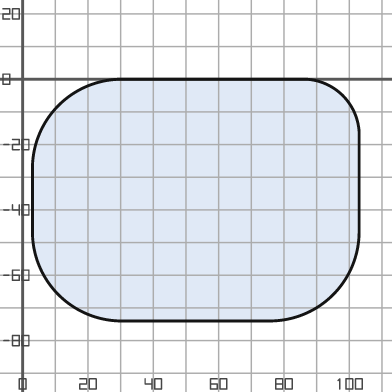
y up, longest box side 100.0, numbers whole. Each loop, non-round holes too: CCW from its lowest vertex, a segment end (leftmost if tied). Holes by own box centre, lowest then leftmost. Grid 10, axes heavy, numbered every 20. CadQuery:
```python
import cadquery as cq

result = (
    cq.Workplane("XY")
    .moveTo(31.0, -74.0)
    .lineTo(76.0, -74.0)
    .threePointArc((95.0, -66.0), (103.0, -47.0))
    .lineTo(103.0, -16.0)
    .threePointArc((98.0, -5.0), (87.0, 0.0))
    .lineTo(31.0, 0.0)
    .threePointArc((11.0, -8.0), (3.0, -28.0))
    .lineTo(3.0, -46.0)
    .threePointArc((11.0, -66.0), (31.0, -74.0))
    .close()
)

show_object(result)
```